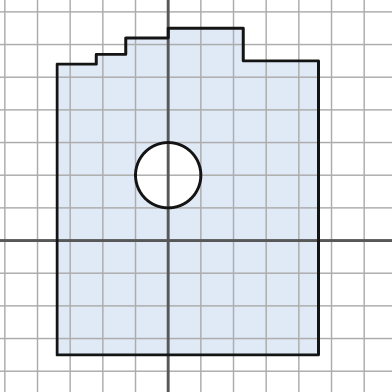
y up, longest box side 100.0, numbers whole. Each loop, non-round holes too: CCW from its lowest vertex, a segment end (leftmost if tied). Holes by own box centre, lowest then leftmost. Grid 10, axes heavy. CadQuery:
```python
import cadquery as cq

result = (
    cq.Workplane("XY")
    .moveTo(-34.0, -35.0)
    .lineTo(46.0, -35.0)
    .lineTo(46.0, 55.0)
    .lineTo(23.0, 55.0)
    .lineTo(23.0, 65.0)
    .lineTo(0.0, 65.0)
    .lineTo(0.0, 62.0)
    .lineTo(-13.0, 62.0)
    .lineTo(-13.0, 57.0)
    .lineTo(-22.0, 57.0)
    .lineTo(-22.0, 54.0)
    .lineTo(-34.0, 54.0)
    .close()
    .moveTo(0.0, 20.0)
    .circle(10.0)
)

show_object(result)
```